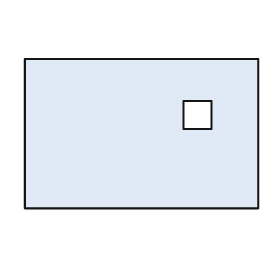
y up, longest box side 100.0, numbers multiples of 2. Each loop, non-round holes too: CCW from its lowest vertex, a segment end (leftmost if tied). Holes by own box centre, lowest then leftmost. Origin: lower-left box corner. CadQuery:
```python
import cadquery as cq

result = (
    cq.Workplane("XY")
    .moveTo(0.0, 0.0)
    .lineTo(100.0, 0.0)
    .lineTo(100.0, 64.0)
    .lineTo(0.0, 64.0)
    .close()
    .moveTo(68.0, 34.0)
    .lineTo(80.0, 34.0)
    .lineTo(80.0, 46.0)
    .lineTo(68.0, 46.0)
    .close()
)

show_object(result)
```